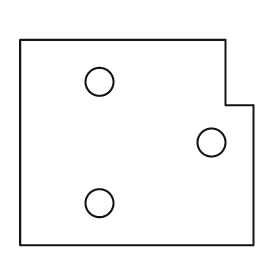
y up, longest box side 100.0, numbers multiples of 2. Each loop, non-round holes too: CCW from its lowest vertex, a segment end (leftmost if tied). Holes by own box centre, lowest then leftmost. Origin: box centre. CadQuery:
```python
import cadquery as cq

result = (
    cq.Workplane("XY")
    .moveTo(-50.0, -44.0)
    .lineTo(50.0, -44.0)
    .lineTo(50.0, 16.0)
    .lineTo(38.0, 16.0)
    .lineTo(38.0, 44.0)
    .lineTo(-50.0, 44.0)
    .close()
    .moveTo(-16.0, -26.0)
    .circle(6.0)
    .moveTo(32.0, 0.0)
    .circle(6.0)
    .moveTo(-16.0, 26.0)
    .circle(6.0)
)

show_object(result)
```